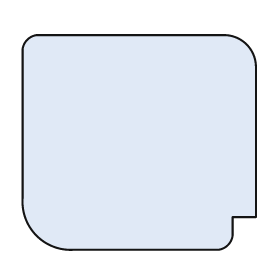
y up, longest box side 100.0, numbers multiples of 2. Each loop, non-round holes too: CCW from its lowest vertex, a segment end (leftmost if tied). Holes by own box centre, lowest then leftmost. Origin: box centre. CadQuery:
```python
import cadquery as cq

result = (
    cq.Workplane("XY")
    .moveTo(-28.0, -46.0)
    .lineTo(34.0, -46.0)
    .threePointArc((38.0, -44.0), (40.0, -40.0))
    .lineTo(40.0, -32.0)
    .lineTo(50.0, -32.0)
    .lineTo(50.0, 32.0)
    .threePointArc((46.0, 42.0), (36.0, 46.0))
    .lineTo(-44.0, 46.0)
    .threePointArc((-48.0, 44.0), (-50.0, 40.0))
    .lineTo(-50.0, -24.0)
    .threePointArc((-44.0, -40.0), (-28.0, -46.0))
    .close()
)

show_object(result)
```